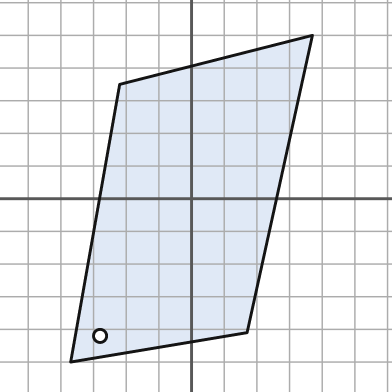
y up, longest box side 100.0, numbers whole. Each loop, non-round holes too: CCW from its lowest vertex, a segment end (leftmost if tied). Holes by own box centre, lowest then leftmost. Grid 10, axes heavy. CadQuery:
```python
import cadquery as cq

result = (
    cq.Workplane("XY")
    .moveTo(-37.0, -50.0)
    .lineTo(17.0, -41.0)
    .lineTo(37.0, 50.0)
    .lineTo(-22.0, 35.0)
    .close()
    .moveTo(-28.0, -42.0)
    .circle(2.0)
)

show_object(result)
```